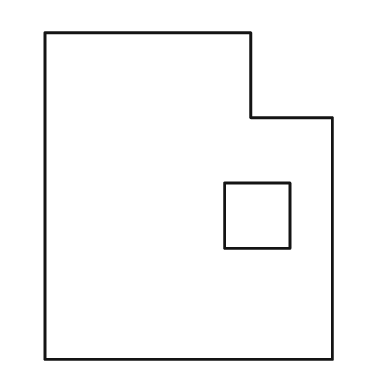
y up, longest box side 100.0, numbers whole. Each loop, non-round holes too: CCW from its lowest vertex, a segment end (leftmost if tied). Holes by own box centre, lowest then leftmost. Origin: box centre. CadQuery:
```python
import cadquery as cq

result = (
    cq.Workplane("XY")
    .moveTo(-44.0, -50.0)
    .lineTo(44.0, -50.0)
    .lineTo(44.0, 24.0)
    .lineTo(19.0, 24.0)
    .lineTo(19.0, 50.0)
    .lineTo(-44.0, 50.0)
    .close()
    .moveTo(11.0, -16.0)
    .lineTo(31.0, -16.0)
    .lineTo(31.0, 4.0)
    .lineTo(11.0, 4.0)
    .close()
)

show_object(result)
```